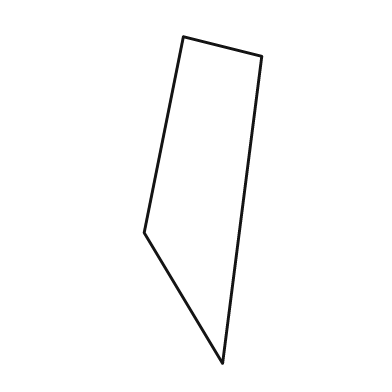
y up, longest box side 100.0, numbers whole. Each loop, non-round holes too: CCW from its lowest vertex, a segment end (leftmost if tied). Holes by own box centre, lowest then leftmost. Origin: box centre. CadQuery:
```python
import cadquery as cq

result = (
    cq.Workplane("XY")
    .moveTo(6.0, -50.0)
    .lineTo(18.0, 44.0)
    .lineTo(-6.0, 50.0)
    .lineTo(-18.0, -10.0)
    .close()
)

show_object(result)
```